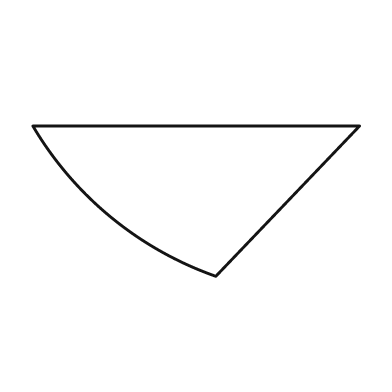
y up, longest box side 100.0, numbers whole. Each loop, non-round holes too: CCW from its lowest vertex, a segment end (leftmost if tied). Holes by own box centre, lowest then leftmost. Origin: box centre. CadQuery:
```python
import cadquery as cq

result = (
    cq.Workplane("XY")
    .moveTo(6.0, -23.0)
    .lineTo(50.0, 23.0)
    .lineTo(-50.0, 23.0)
    .threePointArc((-26.0, -5.0), (6.0, -23.0))
    .close()
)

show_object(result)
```